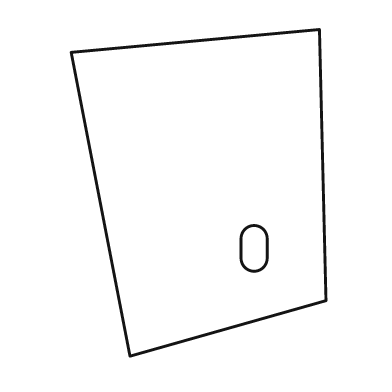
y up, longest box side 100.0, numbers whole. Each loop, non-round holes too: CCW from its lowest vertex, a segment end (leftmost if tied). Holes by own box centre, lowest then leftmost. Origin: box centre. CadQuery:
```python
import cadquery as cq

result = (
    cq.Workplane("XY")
    .moveTo(-21.0, -50.0)
    .lineTo(39.0, -33.0)
    .lineTo(37.0, 50.0)
    .lineTo(-39.0, 43.0)
    .close()
    .moveTo(13.0, -20.0)
    .threePointArc((17.0, -24.0), (21.0, -20.0))
    .lineTo(21.0, -14.0)
    .threePointArc((17.0, -10.0), (13.0, -14.0))
    .close()
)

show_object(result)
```